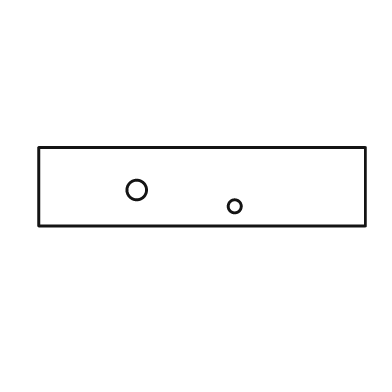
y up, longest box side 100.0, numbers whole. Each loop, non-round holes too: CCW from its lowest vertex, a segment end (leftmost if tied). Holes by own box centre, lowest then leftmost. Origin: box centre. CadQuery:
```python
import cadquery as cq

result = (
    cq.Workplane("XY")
    .moveTo(-50.0, -12.0)
    .lineTo(50.0, -12.0)
    .lineTo(50.0, 12.0)
    .lineTo(-50.0, 12.0)
    .close()
    .moveTo(10.0, -6.0)
    .circle(2.0)
    .moveTo(-20.0, -1.0)
    .circle(3.0)
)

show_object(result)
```